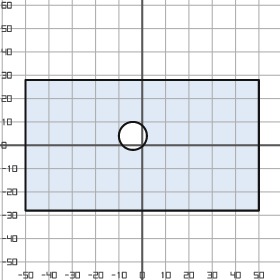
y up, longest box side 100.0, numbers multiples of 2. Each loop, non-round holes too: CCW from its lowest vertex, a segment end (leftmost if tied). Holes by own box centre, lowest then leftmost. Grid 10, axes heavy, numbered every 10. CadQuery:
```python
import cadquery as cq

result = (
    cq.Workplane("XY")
    .moveTo(-50.0, -28.0)
    .lineTo(50.0, -28.0)
    .lineTo(50.0, 28.0)
    .lineTo(-50.0, 28.0)
    .close()
    .moveTo(-4.0, 4.0)
    .circle(6.0)
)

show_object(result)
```